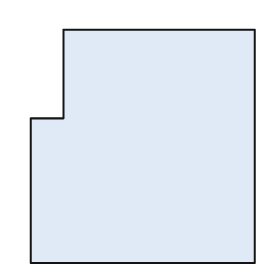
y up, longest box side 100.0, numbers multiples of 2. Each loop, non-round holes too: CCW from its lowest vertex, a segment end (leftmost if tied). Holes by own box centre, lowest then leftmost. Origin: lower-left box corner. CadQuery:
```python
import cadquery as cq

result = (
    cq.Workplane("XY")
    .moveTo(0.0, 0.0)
    .lineTo(96.0, 0.0)
    .lineTo(96.0, 100.0)
    .lineTo(14.0, 100.0)
    .lineTo(14.0, 62.0)
    .lineTo(0.0, 62.0)
    .close()
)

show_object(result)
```